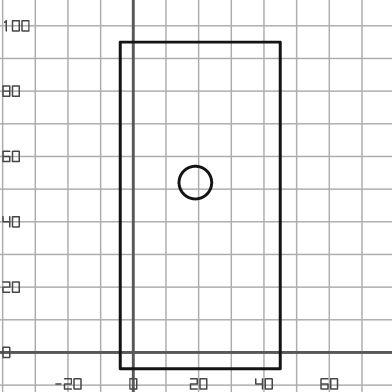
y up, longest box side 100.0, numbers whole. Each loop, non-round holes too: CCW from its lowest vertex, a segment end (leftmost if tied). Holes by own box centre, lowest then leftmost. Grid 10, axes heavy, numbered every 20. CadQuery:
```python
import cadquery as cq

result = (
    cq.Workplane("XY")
    .moveTo(-4.0, -5.0)
    .lineTo(45.0, -5.0)
    .lineTo(45.0, 95.0)
    .lineTo(-4.0, 95.0)
    .close()
    .moveTo(19.0, 52.0)
    .circle(5.0)
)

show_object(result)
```